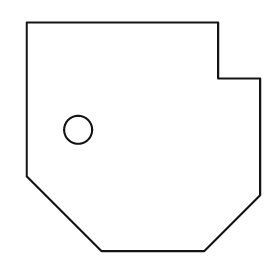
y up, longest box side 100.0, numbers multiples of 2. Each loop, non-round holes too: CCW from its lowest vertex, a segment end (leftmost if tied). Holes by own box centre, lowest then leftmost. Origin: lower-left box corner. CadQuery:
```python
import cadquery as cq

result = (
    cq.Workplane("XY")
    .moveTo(32.0, 0.0)
    .lineTo(76.0, 0.0)
    .lineTo(100.0, 24.0)
    .lineTo(100.0, 74.0)
    .lineTo(82.0, 74.0)
    .lineTo(82.0, 98.0)
    .lineTo(0.0, 98.0)
    .lineTo(0.0, 32.0)
    .close()
    .moveTo(22.0, 52.0)
    .circle(6.0)
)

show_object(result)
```